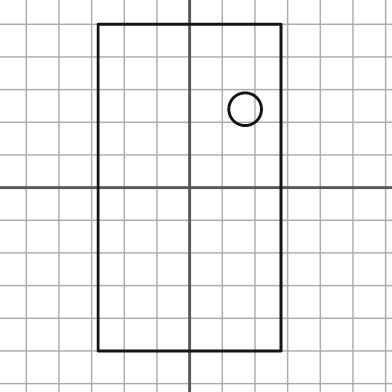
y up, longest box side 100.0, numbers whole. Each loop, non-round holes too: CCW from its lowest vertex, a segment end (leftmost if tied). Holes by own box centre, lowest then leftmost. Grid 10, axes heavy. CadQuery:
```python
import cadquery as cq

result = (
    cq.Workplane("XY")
    .moveTo(-28.0, -50.0)
    .lineTo(28.0, -50.0)
    .lineTo(28.0, 50.0)
    .lineTo(-28.0, 50.0)
    .close()
    .moveTo(17.0, 24.0)
    .circle(5.0)
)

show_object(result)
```